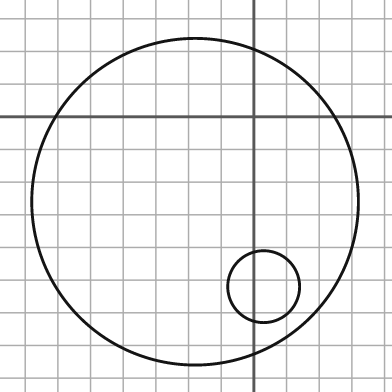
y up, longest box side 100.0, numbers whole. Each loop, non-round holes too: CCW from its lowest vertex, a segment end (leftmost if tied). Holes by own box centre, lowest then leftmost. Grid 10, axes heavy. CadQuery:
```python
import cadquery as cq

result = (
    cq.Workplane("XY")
    .moveTo(-18.0, -26.0)
    .circle(50.0)
    .moveTo(3.0, -52.0)
    .circle(11.0)
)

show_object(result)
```